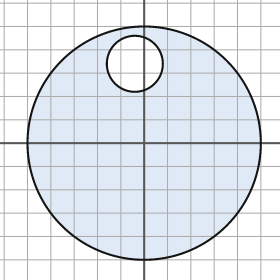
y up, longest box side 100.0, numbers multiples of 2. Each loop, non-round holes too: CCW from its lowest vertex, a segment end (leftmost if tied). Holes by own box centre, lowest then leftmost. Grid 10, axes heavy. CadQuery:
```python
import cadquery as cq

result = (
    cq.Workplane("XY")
    .moveTo(0.0, 0.0)
    .circle(50.0)
    .moveTo(-4.0, 34.0)
    .circle(12.0)
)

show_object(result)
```